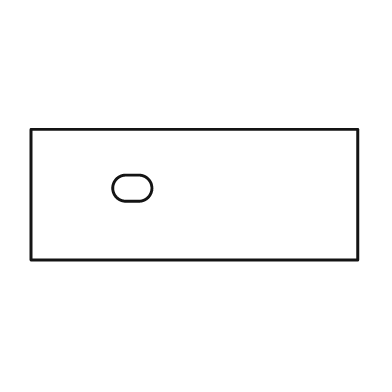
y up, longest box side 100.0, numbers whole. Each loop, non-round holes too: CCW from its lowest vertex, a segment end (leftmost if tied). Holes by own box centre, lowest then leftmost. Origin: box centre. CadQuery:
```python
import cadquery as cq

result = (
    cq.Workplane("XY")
    .moveTo(-50.0, -20.0)
    .lineTo(50.0, -20.0)
    .lineTo(50.0, 20.0)
    .lineTo(-50.0, 20.0)
    .close()
    .moveTo(-21.0, -2.0)
    .lineTo(-17.0, -2.0)
    .threePointArc((-13.0, 2.0), (-17.0, 6.0))
    .lineTo(-21.0, 6.0)
    .threePointArc((-25.0, 2.0), (-21.0, -2.0))
    .close()
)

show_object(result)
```